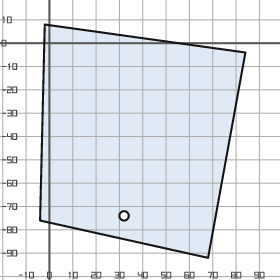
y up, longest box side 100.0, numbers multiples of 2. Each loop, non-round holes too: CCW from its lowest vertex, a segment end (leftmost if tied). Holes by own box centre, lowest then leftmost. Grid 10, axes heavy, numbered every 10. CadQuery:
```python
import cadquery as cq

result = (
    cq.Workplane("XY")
    .moveTo(68.0, -92.0)
    .lineTo(84.0, -4.0)
    .lineTo(-2.0, 8.0)
    .lineTo(-4.0, -76.0)
    .close()
    .moveTo(32.0, -74.0)
    .circle(2.0)
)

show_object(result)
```